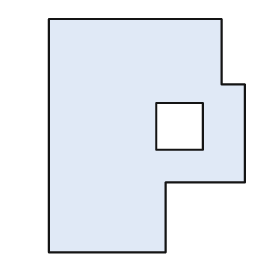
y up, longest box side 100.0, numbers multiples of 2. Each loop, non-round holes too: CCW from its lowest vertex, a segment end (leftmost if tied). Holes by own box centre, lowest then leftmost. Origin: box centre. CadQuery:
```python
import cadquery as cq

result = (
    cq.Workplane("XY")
    .moveTo(-42.0, -50.0)
    .lineTo(8.0, -50.0)
    .lineTo(8.0, -20.0)
    .lineTo(42.0, -20.0)
    .lineTo(42.0, 22.0)
    .lineTo(32.0, 22.0)
    .lineTo(32.0, 50.0)
    .lineTo(-42.0, 50.0)
    .close()
    .moveTo(4.0, -6.0)
    .lineTo(24.0, -6.0)
    .lineTo(24.0, 14.0)
    .lineTo(4.0, 14.0)
    .close()
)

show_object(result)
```